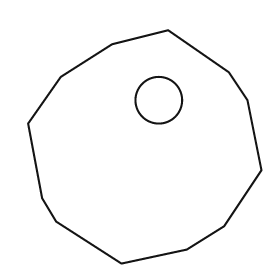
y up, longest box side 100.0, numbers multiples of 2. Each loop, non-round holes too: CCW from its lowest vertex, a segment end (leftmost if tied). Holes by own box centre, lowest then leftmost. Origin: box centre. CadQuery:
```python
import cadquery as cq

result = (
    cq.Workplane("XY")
    .moveTo(-10.0, -50.0)
    .lineTo(18.0, -44.0)
    .lineTo(34.0, -34.0)
    .lineTo(50.0, -10.0)
    .lineTo(44.0, 20.0)
    .lineTo(36.0, 32.0)
    .lineTo(10.0, 50.0)
    .lineTo(-14.0, 44.0)
    .lineTo(-36.0, 30.0)
    .lineTo(-50.0, 10.0)
    .lineTo(-44.0, -22.0)
    .lineTo(-38.0, -32.0)
    .close()
    .moveTo(6.0, 20.0)
    .circle(10.0)
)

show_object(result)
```